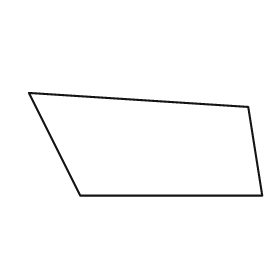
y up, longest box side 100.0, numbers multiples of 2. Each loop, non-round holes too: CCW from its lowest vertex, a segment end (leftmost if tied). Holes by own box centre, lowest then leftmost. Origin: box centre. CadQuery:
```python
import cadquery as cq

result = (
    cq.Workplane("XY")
    .moveTo(-28.0, -22.0)
    .lineTo(50.0, -22.0)
    .lineTo(44.0, 16.0)
    .lineTo(-50.0, 22.0)
    .close()
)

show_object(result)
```